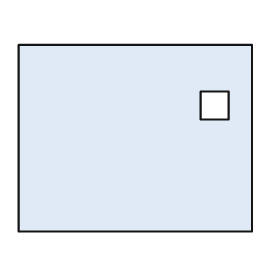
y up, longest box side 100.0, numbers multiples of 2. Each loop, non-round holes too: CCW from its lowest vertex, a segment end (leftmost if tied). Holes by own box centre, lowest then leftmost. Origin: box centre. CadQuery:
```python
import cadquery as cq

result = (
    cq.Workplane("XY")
    .moveTo(-50.0, -40.0)
    .lineTo(50.0, -40.0)
    .lineTo(50.0, 40.0)
    .lineTo(-50.0, 40.0)
    .close()
    .moveTo(28.0, 8.0)
    .lineTo(40.0, 8.0)
    .lineTo(40.0, 20.0)
    .lineTo(28.0, 20.0)
    .close()
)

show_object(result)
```